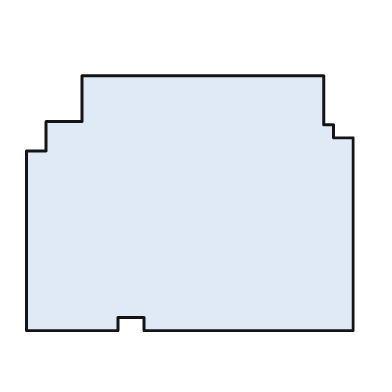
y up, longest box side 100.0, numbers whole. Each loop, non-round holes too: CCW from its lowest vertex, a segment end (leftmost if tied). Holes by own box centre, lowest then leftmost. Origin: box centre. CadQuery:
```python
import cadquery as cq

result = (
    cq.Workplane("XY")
    .moveTo(-50.0, -39.0)
    .lineTo(-22.0, -39.0)
    .lineTo(-22.0, -35.0)
    .lineTo(-14.0, -35.0)
    .lineTo(-14.0, -39.0)
    .lineTo(50.0, -39.0)
    .lineTo(50.0, 20.0)
    .lineTo(44.0, 20.0)
    .lineTo(44.0, 24.0)
    .lineTo(41.0, 24.0)
    .lineTo(41.0, 39.0)
    .lineTo(-33.0, 39.0)
    .lineTo(-33.0, 25.0)
    .lineTo(-44.0, 25.0)
    .lineTo(-44.0, 16.0)
    .lineTo(-50.0, 16.0)
    .close()
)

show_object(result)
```